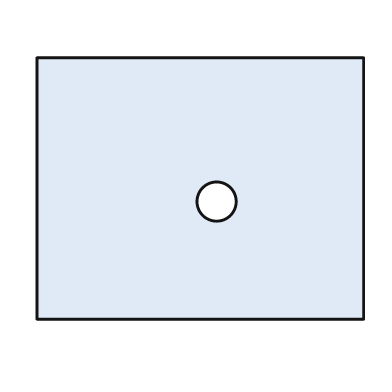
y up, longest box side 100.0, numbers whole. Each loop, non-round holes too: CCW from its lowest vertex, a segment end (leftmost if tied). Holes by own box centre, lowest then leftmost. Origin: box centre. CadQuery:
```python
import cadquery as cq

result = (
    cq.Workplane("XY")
    .moveTo(-50.0, -40.0)
    .lineTo(50.0, -40.0)
    .lineTo(50.0, 40.0)
    .lineTo(-50.0, 40.0)
    .close()
    .moveTo(5.0, -4.0)
    .circle(6.0)
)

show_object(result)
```